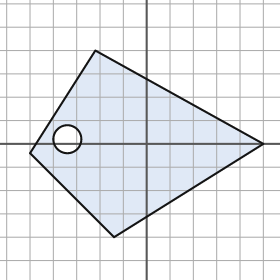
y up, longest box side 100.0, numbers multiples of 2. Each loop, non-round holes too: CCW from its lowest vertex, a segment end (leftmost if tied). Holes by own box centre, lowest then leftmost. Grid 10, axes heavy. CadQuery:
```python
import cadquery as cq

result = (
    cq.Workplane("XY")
    .moveTo(-14.0, -40.0)
    .lineTo(50.0, 0.0)
    .lineTo(-22.0, 40.0)
    .lineTo(-50.0, -4.0)
    .close()
    .moveTo(-34.0, 2.0)
    .circle(6.0)
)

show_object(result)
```